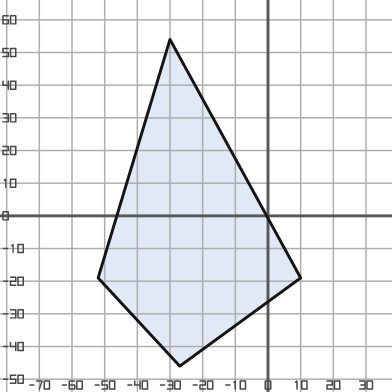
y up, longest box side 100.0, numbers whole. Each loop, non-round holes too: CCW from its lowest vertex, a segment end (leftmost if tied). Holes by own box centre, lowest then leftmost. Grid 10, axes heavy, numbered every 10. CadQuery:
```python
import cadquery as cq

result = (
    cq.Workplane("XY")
    .moveTo(-27.0, -46.0)
    .lineTo(10.0, -19.0)
    .lineTo(-30.0, 54.0)
    .lineTo(-52.0, -19.0)
    .close()
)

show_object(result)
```